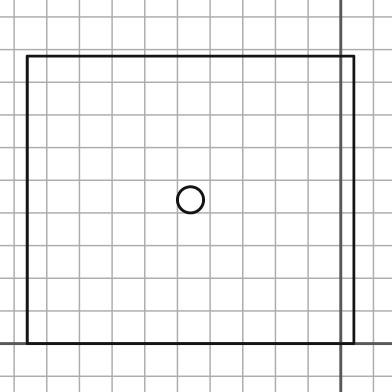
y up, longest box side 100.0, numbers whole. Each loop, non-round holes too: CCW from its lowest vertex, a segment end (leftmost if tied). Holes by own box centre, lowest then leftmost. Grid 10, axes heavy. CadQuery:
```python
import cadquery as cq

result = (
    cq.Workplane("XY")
    .moveTo(-96.0, 0.0)
    .lineTo(4.0, 0.0)
    .lineTo(4.0, 88.0)
    .lineTo(-96.0, 88.0)
    .close()
    .moveTo(-46.0, 44.0)
    .circle(4.0)
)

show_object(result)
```